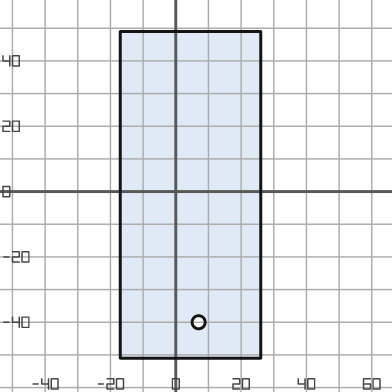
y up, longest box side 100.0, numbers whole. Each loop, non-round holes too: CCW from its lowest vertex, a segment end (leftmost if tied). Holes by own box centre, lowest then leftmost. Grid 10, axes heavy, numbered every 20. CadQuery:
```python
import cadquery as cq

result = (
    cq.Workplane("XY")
    .moveTo(-17.0, -51.0)
    .lineTo(26.0, -51.0)
    .lineTo(26.0, 49.0)
    .lineTo(-17.0, 49.0)
    .close()
    .moveTo(7.0, -40.0)
    .circle(2.0)
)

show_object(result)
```